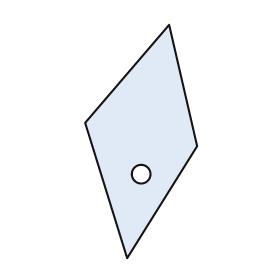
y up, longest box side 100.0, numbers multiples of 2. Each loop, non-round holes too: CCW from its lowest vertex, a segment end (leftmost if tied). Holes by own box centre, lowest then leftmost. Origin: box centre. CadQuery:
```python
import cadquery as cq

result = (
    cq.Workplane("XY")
    .moveTo(-6.0, -50.0)
    .lineTo(24.0, -2.0)
    .lineTo(12.0, 50.0)
    .lineTo(-24.0, 8.0)
    .close()
    .moveTo(0.0, -14.0)
    .circle(4.0)
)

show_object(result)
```